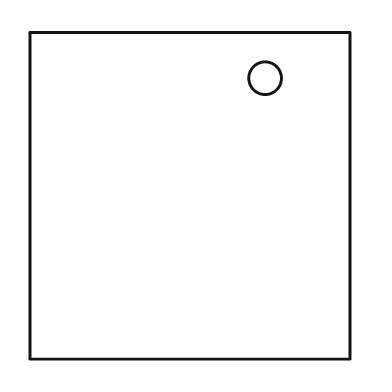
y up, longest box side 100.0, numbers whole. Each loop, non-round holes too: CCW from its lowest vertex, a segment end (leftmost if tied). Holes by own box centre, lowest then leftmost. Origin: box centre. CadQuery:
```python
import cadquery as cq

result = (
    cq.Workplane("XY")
    .moveTo(-49.0, -50.0)
    .lineTo(49.0, -50.0)
    .lineTo(49.0, 50.0)
    .lineTo(-49.0, 50.0)
    .close()
    .moveTo(23.0, 36.0)
    .circle(5.0)
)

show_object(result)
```